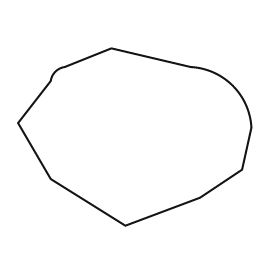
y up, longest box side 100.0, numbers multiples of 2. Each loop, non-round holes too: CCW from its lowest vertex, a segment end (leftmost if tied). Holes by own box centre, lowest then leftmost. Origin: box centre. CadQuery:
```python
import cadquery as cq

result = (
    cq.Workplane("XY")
    .moveTo(-4.0, -38.0)
    .lineTo(28.0, -26.0)
    .lineTo(46.0, -14.0)
    .lineTo(50.0, 4.0)
    .threePointArc((42.0, 22.0), (24.0, 30.0))
    .lineTo(-10.0, 38.0)
    .lineTo(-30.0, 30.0)
    .threePointArc((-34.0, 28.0), (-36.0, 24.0))
    .lineTo(-50.0, 6.0)
    .lineTo(-36.0, -18.0)
    .close()
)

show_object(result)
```